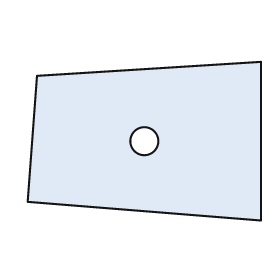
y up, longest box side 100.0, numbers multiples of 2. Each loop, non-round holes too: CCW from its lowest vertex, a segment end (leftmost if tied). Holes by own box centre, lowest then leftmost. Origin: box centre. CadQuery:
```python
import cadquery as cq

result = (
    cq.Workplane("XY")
    .moveTo(50.0, -34.0)
    .lineTo(50.0, 34.0)
    .lineTo(-46.0, 28.0)
    .lineTo(-50.0, -26.0)
    .close()
    .moveTo(0.0, 0.0)
    .circle(6.0)
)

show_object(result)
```